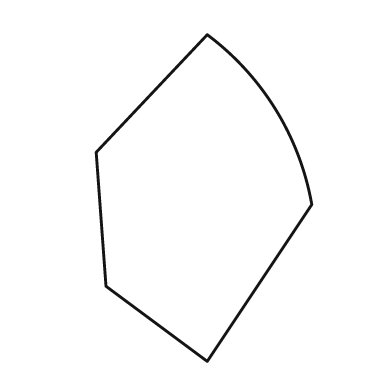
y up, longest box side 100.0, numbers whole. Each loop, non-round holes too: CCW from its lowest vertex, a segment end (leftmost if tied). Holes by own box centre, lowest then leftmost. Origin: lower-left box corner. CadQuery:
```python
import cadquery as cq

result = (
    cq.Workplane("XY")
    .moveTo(34.0, 0.0)
    .lineTo(66.0, 48.0)
    .threePointArc((55.0, 77.0), (34.0, 100.0))
    .lineTo(0.0, 64.0)
    .lineTo(3.0, 23.0)
    .close()
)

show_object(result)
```